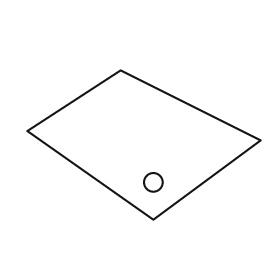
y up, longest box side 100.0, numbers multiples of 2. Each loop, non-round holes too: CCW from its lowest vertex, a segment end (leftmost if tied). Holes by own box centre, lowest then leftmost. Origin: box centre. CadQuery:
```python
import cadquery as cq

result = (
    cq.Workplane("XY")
    .moveTo(4.0, -32.0)
    .lineTo(50.0, 2.0)
    .lineTo(-10.0, 32.0)
    .lineTo(-50.0, 6.0)
    .close()
    .moveTo(4.0, -16.0)
    .circle(4.0)
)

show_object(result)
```